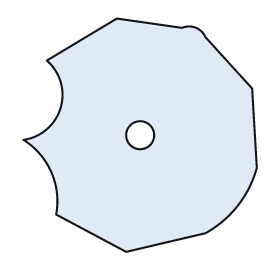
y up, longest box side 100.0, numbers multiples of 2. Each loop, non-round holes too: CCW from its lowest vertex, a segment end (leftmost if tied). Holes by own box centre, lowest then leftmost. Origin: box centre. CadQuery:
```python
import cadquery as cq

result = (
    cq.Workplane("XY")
    .moveTo(-6.0, -50.0)
    .lineTo(28.0, -42.0)
    .threePointArc((42.0, -30.0), (50.0, -14.0))
    .lineTo(48.0, 20.0)
    .lineTo(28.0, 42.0)
    .threePointArc((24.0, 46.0), (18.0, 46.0))
    .lineTo(-10.0, 50.0)
    .lineTo(-40.0, 32.0)
    .threePointArc((-34.0, 12.0), (-50.0, -2.0))
    .threePointArc((-38.0, -16.0), (-36.0, -34.0))
    .close()
    .moveTo(0.0, 0.0)
    .circle(6.0)
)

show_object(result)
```